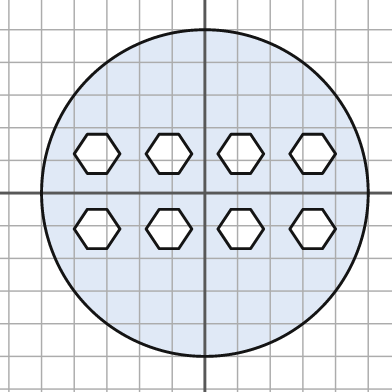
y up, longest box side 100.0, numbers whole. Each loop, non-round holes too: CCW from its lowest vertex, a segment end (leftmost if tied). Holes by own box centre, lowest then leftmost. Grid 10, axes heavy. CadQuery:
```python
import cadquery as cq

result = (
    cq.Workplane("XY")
    .moveTo(0.0, 0.0)
    .circle(50.0)
    .moveTo(-36.0, -17.0)
    .lineTo(-30.0, -17.0)
    .lineTo(-26.0, -11.0)
    .lineTo(-30.0, -5.0)
    .lineTo(-36.0, -5.0)
    .lineTo(-40.0, -11.0)
    .close()
    .moveTo(-14.0, -17.0)
    .lineTo(-8.0, -17.0)
    .lineTo(-4.0, -11.0)
    .lineTo(-8.0, -5.0)
    .lineTo(-14.0, -5.0)
    .lineTo(-18.0, -11.0)
    .close()
    .moveTo(8.0, -17.0)
    .lineTo(14.0, -17.0)
    .lineTo(18.0, -11.0)
    .lineTo(14.0, -5.0)
    .lineTo(8.0, -5.0)
    .lineTo(4.0, -11.0)
    .close()
    .moveTo(30.0, -17.0)
    .lineTo(36.0, -17.0)
    .lineTo(40.0, -11.0)
    .lineTo(36.0, -5.0)
    .lineTo(30.0, -5.0)
    .lineTo(26.0, -11.0)
    .close()
    .moveTo(-36.0, 6.0)
    .lineTo(-30.0, 6.0)
    .lineTo(-26.0, 12.0)
    .lineTo(-30.0, 18.0)
    .lineTo(-36.0, 18.0)
    .lineTo(-40.0, 12.0)
    .close()
    .moveTo(-14.0, 6.0)
    .lineTo(-8.0, 6.0)
    .lineTo(-4.0, 12.0)
    .lineTo(-8.0, 18.0)
    .lineTo(-14.0, 18.0)
    .lineTo(-18.0, 12.0)
    .close()
    .moveTo(8.0, 6.0)
    .lineTo(14.0, 6.0)
    .lineTo(18.0, 12.0)
    .lineTo(14.0, 18.0)
    .lineTo(8.0, 18.0)
    .lineTo(4.0, 12.0)
    .close()
    .moveTo(30.0, 6.0)
    .lineTo(36.0, 6.0)
    .lineTo(40.0, 12.0)
    .lineTo(36.0, 18.0)
    .lineTo(30.0, 18.0)
    .lineTo(26.0, 12.0)
    .close()
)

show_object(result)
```